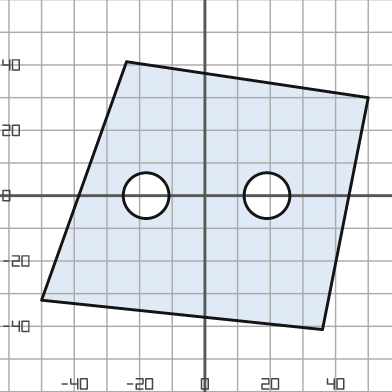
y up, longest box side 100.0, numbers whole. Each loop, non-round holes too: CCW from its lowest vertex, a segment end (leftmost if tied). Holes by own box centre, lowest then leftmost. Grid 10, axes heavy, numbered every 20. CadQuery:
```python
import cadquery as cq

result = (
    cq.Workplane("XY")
    .moveTo(36.0, -41.0)
    .lineTo(50.0, 30.0)
    .lineTo(-24.0, 41.0)
    .lineTo(-50.0, -32.0)
    .close()
    .moveTo(-18.0, 0.0)
    .circle(7.0)
    .moveTo(19.0, 0.0)
    .circle(7.0)
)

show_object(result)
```